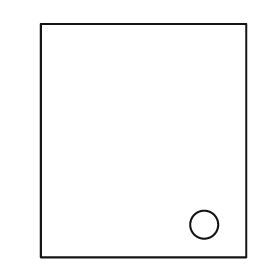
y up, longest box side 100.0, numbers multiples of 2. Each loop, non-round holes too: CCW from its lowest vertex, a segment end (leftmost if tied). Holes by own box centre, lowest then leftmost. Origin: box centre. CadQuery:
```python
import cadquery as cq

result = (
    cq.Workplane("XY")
    .moveTo(-44.0, -50.0)
    .lineTo(44.0, -50.0)
    .lineTo(44.0, 50.0)
    .lineTo(-44.0, 50.0)
    .close()
    .moveTo(26.0, -36.0)
    .circle(6.0)
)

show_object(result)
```